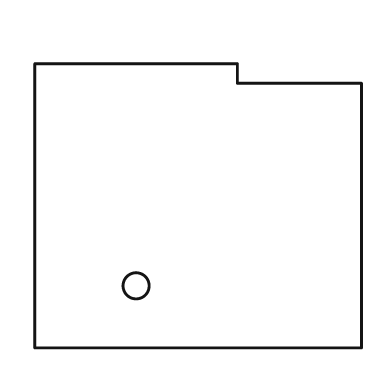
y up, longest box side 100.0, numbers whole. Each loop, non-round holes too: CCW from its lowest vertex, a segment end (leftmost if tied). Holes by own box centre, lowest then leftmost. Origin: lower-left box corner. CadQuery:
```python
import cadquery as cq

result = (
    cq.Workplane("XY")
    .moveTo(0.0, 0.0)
    .lineTo(100.0, 0.0)
    .lineTo(100.0, 81.0)
    .lineTo(62.0, 81.0)
    .lineTo(62.0, 87.0)
    .lineTo(0.0, 87.0)
    .close()
    .moveTo(31.0, 19.0)
    .circle(4.0)
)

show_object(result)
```